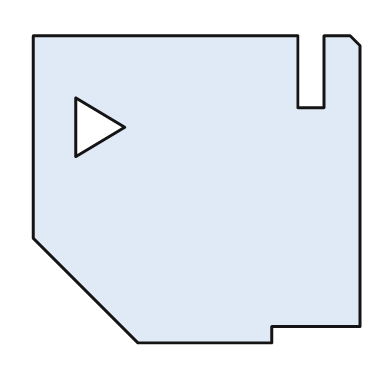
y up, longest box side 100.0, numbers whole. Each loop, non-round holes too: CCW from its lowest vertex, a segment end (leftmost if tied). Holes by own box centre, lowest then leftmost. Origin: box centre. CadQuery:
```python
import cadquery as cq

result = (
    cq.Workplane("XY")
    .moveTo(-18.0, -47.0)
    .lineTo(23.0, -47.0)
    .lineTo(23.0, -42.0)
    .lineTo(50.0, -42.0)
    .lineTo(50.0, 44.0)
    .lineTo(47.0, 47.0)
    .lineTo(39.0, 47.0)
    .lineTo(39.0, 25.0)
    .lineTo(31.0, 25.0)
    .lineTo(31.0, 47.0)
    .lineTo(-50.0, 47.0)
    .lineTo(-50.0, -15.0)
    .close()
    .moveTo(-37.0, 10.0)
    .lineTo(-22.0, 19.0)
    .lineTo(-37.0, 28.0)
    .close()
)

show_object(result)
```